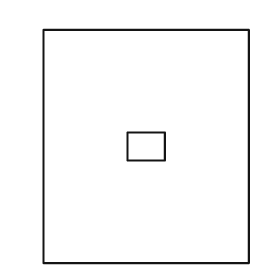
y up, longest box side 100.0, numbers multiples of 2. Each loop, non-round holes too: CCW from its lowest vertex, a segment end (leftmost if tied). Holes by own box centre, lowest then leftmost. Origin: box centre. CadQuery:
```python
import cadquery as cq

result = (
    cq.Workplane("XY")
    .moveTo(-44.0, -50.0)
    .lineTo(44.0, -50.0)
    .lineTo(44.0, 50.0)
    .lineTo(-44.0, 50.0)
    .close()
    .moveTo(-8.0, -6.0)
    .lineTo(8.0, -6.0)
    .lineTo(8.0, 6.0)
    .lineTo(-8.0, 6.0)
    .close()
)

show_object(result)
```